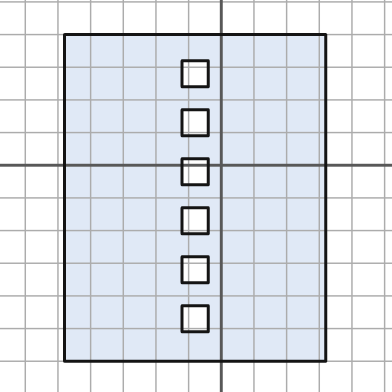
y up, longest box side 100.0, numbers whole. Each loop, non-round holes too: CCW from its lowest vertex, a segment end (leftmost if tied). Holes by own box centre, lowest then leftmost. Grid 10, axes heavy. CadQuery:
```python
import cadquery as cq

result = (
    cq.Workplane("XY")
    .moveTo(-48.0, -60.0)
    .lineTo(32.0, -60.0)
    .lineTo(32.0, 40.0)
    .lineTo(-48.0, 40.0)
    .close()
    .moveTo(-12.0, -51.0)
    .lineTo(-4.0, -51.0)
    .lineTo(-4.0, -43.0)
    .lineTo(-12.0, -43.0)
    .close()
    .moveTo(-12.0, -36.0)
    .lineTo(-4.0, -36.0)
    .lineTo(-4.0, -28.0)
    .lineTo(-12.0, -28.0)
    .close()
    .moveTo(-12.0, -21.0)
    .lineTo(-4.0, -21.0)
    .lineTo(-4.0, -13.0)
    .lineTo(-12.0, -13.0)
    .close()
    .moveTo(-12.0, -6.0)
    .lineTo(-4.0, -6.0)
    .lineTo(-4.0, 2.0)
    .lineTo(-12.0, 2.0)
    .close()
    .moveTo(-12.0, 9.0)
    .lineTo(-4.0, 9.0)
    .lineTo(-4.0, 17.0)
    .lineTo(-12.0, 17.0)
    .close()
    .moveTo(-12.0, 24.0)
    .lineTo(-4.0, 24.0)
    .lineTo(-4.0, 32.0)
    .lineTo(-12.0, 32.0)
    .close()
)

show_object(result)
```